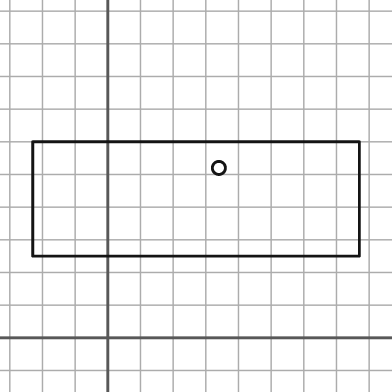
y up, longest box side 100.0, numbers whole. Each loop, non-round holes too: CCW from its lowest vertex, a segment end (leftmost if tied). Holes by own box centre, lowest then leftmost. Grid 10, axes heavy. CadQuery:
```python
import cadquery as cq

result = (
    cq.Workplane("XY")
    .moveTo(-23.0, 25.0)
    .lineTo(77.0, 25.0)
    .lineTo(77.0, 60.0)
    .lineTo(-23.0, 60.0)
    .close()
    .moveTo(34.0, 52.0)
    .circle(2.0)
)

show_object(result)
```